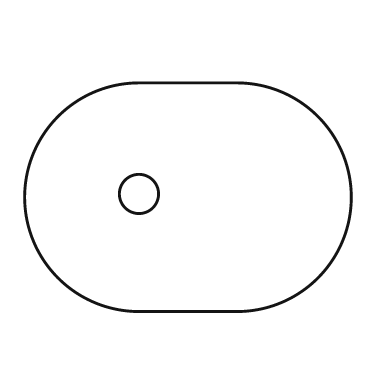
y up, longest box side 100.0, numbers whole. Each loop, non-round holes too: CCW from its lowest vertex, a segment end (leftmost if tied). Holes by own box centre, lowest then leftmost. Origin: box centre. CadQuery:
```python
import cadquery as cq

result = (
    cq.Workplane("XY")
    .moveTo(-15.0, -35.0)
    .lineTo(15.0, -35.0)
    .threePointArc((50.0, 0.0), (15.0, 35.0))
    .lineTo(-15.0, 35.0)
    .threePointArc((-50.0, 0.0), (-15.0, -35.0))
    .close()
    .moveTo(-15.0, 1.0)
    .circle(6.0)
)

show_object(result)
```